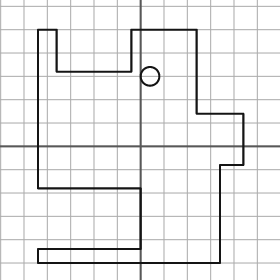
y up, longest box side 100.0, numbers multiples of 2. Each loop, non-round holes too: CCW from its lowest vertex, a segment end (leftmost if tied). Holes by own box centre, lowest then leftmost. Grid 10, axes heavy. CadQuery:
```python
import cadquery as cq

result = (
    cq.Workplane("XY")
    .moveTo(-44.0, -50.0)
    .lineTo(34.0, -50.0)
    .lineTo(34.0, -8.0)
    .lineTo(44.0, -8.0)
    .lineTo(44.0, 14.0)
    .lineTo(24.0, 14.0)
    .lineTo(24.0, 50.0)
    .lineTo(-4.0, 50.0)
    .lineTo(-4.0, 32.0)
    .lineTo(-36.0, 32.0)
    .lineTo(-36.0, 50.0)
    .lineTo(-44.0, 50.0)
    .lineTo(-44.0, -18.0)
    .lineTo(0.0, -18.0)
    .lineTo(0.0, -44.0)
    .lineTo(-44.0, -44.0)
    .close()
    .moveTo(4.0, 30.0)
    .circle(4.0)
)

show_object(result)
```